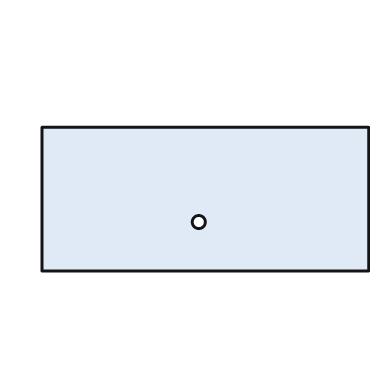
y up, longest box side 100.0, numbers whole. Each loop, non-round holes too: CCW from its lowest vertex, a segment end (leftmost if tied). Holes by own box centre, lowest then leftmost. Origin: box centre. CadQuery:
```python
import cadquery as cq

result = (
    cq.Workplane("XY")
    .moveTo(-50.0, -22.0)
    .lineTo(50.0, -22.0)
    .lineTo(50.0, 22.0)
    .lineTo(-50.0, 22.0)
    .close()
    .moveTo(-2.0, -7.0)
    .circle(2.0)
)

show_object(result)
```